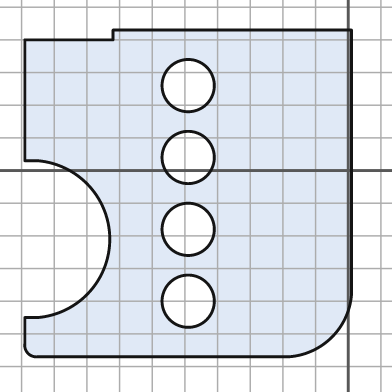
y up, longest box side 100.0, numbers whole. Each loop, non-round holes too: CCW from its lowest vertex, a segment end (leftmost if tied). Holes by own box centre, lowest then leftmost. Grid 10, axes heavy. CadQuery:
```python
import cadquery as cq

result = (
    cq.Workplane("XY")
    .moveTo(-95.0, -57.0)
    .lineTo(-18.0, -57.0)
    .threePointArc((-5.0, -51.0), (1.0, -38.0))
    .lineTo(1.0, 43.0)
    .lineTo(-72.0, 43.0)
    .lineTo(-72.0, 40.0)
    .lineTo(-99.0, 40.0)
    .lineTo(-99.0, 3.0)
    .lineTo(-95.0, 3.0)
    .threePointArc((-73.0, -21.0), (-95.0, -45.0))
    .lineTo(-99.0, -45.0)
    .lineTo(-99.0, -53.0)
    .threePointArc((-98.0, -56.0), (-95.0, -57.0))
    .close()
    .moveTo(-49.0, -40.0)
    .circle(8.0)
    .moveTo(-49.0, -18.0)
    .circle(8.0)
    .moveTo(-49.0, 4.0)
    .circle(8.0)
    .moveTo(-49.0, 26.0)
    .circle(8.0)
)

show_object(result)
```